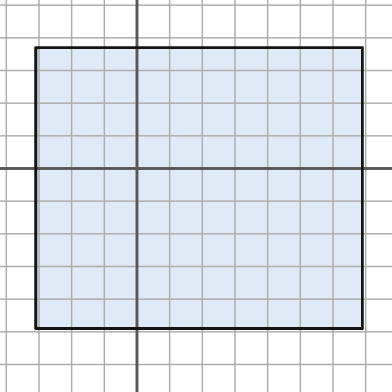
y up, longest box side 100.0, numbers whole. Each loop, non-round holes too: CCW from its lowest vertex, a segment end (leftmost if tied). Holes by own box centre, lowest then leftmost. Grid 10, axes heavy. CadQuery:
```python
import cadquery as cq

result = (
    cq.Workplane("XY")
    .moveTo(-31.0, -49.0)
    .lineTo(69.0, -49.0)
    .lineTo(69.0, 37.0)
    .lineTo(-31.0, 37.0)
    .close()
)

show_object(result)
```